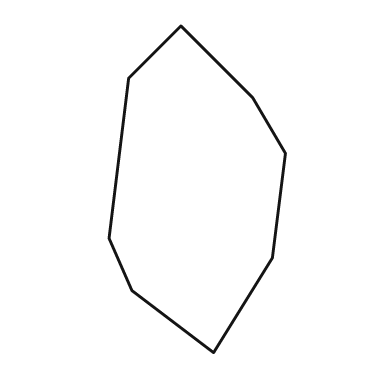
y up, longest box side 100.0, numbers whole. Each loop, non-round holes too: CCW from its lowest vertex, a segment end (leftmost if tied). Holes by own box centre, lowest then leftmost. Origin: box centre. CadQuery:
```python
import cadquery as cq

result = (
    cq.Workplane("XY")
    .moveTo(5.0, -50.0)
    .lineTo(23.0, -21.0)
    .lineTo(27.0, 11.0)
    .lineTo(17.0, 28.0)
    .lineTo(-5.0, 50.0)
    .lineTo(-21.0, 34.0)
    .lineTo(-27.0, -15.0)
    .lineTo(-20.0, -31.0)
    .close()
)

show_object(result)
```